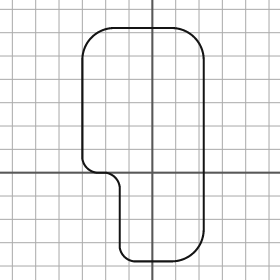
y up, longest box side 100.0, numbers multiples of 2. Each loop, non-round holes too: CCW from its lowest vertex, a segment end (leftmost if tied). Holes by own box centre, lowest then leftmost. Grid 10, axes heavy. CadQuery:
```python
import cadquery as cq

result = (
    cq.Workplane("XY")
    .moveTo(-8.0, -38.0)
    .lineTo(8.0, -38.0)
    .threePointArc((18.0, -34.0), (22.0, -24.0))
    .lineTo(22.0, 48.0)
    .threePointArc((18.0, 58.0), (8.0, 62.0))
    .lineTo(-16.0, 62.0)
    .threePointArc((-26.0, 58.0), (-30.0, 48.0))
    .lineTo(-30.0, 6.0)
    .threePointArc((-28.0, 2.0), (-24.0, 0.0))
    .lineTo(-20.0, 0.0)
    .threePointArc((-16.0, -2.0), (-14.0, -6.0))
    .lineTo(-14.0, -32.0)
    .threePointArc((-12.0, -36.0), (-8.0, -38.0))
    .close()
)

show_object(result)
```